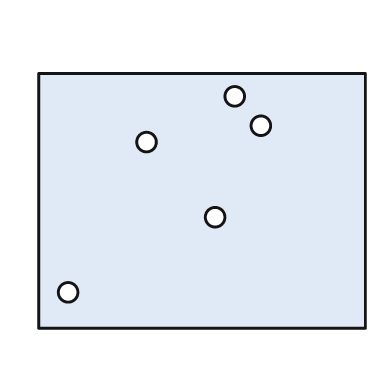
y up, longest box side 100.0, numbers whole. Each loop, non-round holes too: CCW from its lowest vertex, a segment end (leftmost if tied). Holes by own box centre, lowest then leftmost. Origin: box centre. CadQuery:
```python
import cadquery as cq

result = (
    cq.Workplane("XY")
    .moveTo(-50.0, -39.0)
    .lineTo(50.0, -39.0)
    .lineTo(50.0, 39.0)
    .lineTo(-50.0, 39.0)
    .close()
    .moveTo(-41.0, -28.0)
    .circle(3.0)
    .moveTo(4.0, -5.0)
    .circle(3.0)
    .moveTo(-17.0, 18.0)
    .circle(3.0)
    .moveTo(18.0, 23.0)
    .circle(3.0)
    .moveTo(10.0, 32.0)
    .circle(3.0)
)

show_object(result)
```